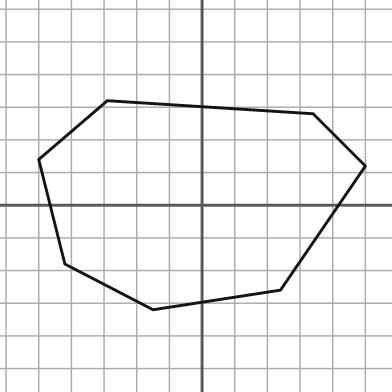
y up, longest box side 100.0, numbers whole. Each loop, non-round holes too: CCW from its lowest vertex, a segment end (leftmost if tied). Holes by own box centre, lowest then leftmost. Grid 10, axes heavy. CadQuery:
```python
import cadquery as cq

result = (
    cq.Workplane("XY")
    .moveTo(-15.0, -32.0)
    .lineTo(24.0, -26.0)
    .lineTo(50.0, 12.0)
    .lineTo(34.0, 28.0)
    .lineTo(-29.0, 32.0)
    .lineTo(-50.0, 14.0)
    .lineTo(-42.0, -18.0)
    .close()
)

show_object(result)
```